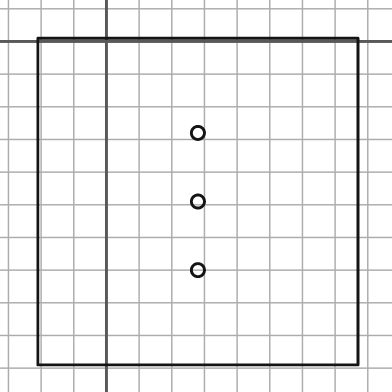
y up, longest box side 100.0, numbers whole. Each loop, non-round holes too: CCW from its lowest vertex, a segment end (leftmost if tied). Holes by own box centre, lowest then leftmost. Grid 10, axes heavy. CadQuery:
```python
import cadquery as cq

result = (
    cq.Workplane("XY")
    .moveTo(-21.0, -99.0)
    .lineTo(77.0, -99.0)
    .lineTo(77.0, 1.0)
    .lineTo(-21.0, 1.0)
    .close()
    .moveTo(28.0, -70.0)
    .circle(2.0)
    .moveTo(28.0, -49.0)
    .circle(2.0)
    .moveTo(28.0, -28.0)
    .circle(2.0)
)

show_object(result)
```